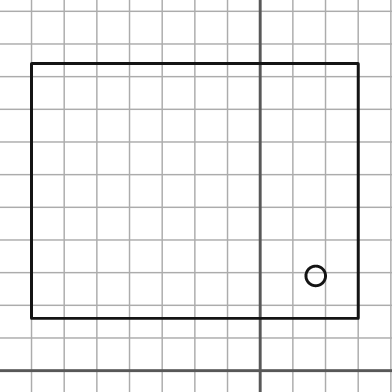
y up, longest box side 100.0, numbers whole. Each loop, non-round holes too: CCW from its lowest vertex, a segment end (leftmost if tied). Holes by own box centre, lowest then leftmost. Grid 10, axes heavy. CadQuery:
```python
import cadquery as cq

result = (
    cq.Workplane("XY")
    .moveTo(-70.0, 16.0)
    .lineTo(30.0, 16.0)
    .lineTo(30.0, 94.0)
    .lineTo(-70.0, 94.0)
    .close()
    .moveTo(17.0, 29.0)
    .circle(3.0)
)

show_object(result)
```